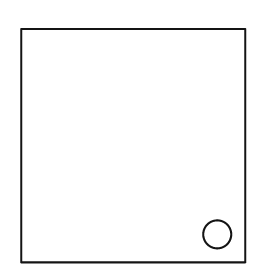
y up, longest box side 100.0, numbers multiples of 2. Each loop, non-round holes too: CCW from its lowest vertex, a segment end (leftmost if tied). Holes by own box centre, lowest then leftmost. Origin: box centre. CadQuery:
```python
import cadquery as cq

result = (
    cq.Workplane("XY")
    .moveTo(-48.0, -50.0)
    .lineTo(48.0, -50.0)
    .lineTo(48.0, 50.0)
    .lineTo(-48.0, 50.0)
    .close()
    .moveTo(36.0, -38.0)
    .circle(6.0)
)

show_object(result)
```